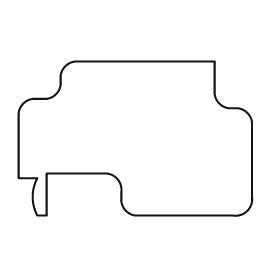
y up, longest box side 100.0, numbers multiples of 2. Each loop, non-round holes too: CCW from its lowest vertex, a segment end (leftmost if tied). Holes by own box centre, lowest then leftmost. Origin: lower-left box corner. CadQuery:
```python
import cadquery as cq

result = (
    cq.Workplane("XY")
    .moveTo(8.0, 0.0)
    .lineTo(12.0, 0.0)
    .lineTo(12.0, 18.0)
    .lineTo(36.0, 18.0)
    .threePointArc((42.0, 16.0), (44.0, 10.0))
    .lineTo(44.0, 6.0)
    .threePointArc((46.0, 2.0), (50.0, 0.0))
    .lineTo(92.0, 0.0)
    .threePointArc((98.0, 2.0), (100.0, 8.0))
    .lineTo(100.0, 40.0)
    .threePointArc((98.0, 44.0), (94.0, 46.0))
    .lineTo(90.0, 46.0)
    .threePointArc((86.0, 48.0), (84.0, 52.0))
    .lineTo(84.0, 66.0)
    .lineTo(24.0, 66.0)
    .threePointArc((20.0, 64.0), (18.0, 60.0))
    .lineTo(18.0, 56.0)
    .threePointArc((16.0, 52.0), (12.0, 50.0))
    .lineTo(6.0, 50.0)
    .threePointArc((2.0, 48.0), (0.0, 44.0))
    .lineTo(0.0, 16.0)
    .lineTo(8.0, 16.0)
    .threePointArc((6.0, 8.0), (8.0, 0.0))
    .close()
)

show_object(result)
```